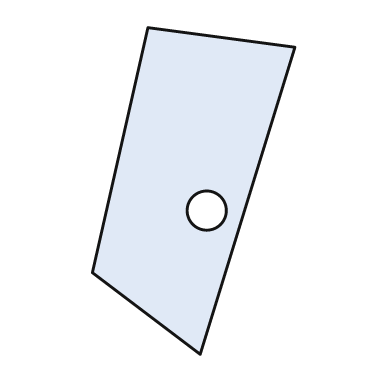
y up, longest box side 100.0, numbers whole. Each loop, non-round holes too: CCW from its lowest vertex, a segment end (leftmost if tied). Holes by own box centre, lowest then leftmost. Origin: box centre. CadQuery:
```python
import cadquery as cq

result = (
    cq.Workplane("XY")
    .moveTo(2.0, -50.0)
    .lineTo(31.0, 44.0)
    .lineTo(-14.0, 50.0)
    .lineTo(-31.0, -25.0)
    .close()
    .moveTo(4.0, -6.0)
    .circle(6.0)
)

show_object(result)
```